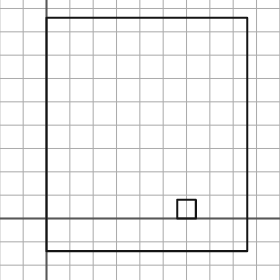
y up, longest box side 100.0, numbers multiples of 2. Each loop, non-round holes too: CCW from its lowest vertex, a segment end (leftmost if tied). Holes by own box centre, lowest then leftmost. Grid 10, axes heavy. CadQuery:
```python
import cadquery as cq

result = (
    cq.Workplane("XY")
    .moveTo(0.0, -14.0)
    .lineTo(86.0, -14.0)
    .lineTo(86.0, 86.0)
    .lineTo(0.0, 86.0)
    .close()
    .moveTo(56.0, 0.0)
    .lineTo(64.0, 0.0)
    .lineTo(64.0, 8.0)
    .lineTo(56.0, 8.0)
    .close()
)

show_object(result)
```